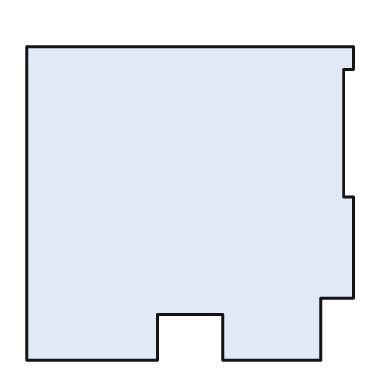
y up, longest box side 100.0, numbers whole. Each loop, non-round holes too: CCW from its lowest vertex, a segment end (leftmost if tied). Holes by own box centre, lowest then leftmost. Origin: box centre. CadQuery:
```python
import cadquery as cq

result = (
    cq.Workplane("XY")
    .moveTo(-50.0, -48.0)
    .lineTo(-10.0, -48.0)
    .lineTo(-10.0, -34.0)
    .lineTo(10.0, -34.0)
    .lineTo(10.0, -48.0)
    .lineTo(40.0, -48.0)
    .lineTo(40.0, -29.0)
    .lineTo(50.0, -29.0)
    .lineTo(50.0, 2.0)
    .lineTo(47.0, 2.0)
    .lineTo(47.0, 41.0)
    .lineTo(50.0, 41.0)
    .lineTo(50.0, 48.0)
    .lineTo(-50.0, 48.0)
    .close()
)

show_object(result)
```